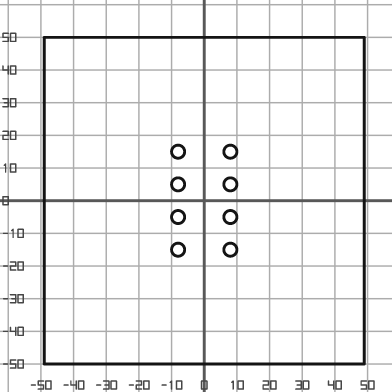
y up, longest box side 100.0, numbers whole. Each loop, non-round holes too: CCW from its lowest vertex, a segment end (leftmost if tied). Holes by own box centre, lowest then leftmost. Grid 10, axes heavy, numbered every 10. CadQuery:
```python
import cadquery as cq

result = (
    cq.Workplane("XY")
    .moveTo(-49.0, -50.0)
    .lineTo(49.0, -50.0)
    .lineTo(49.0, 50.0)
    .lineTo(-49.0, 50.0)
    .close()
    .moveTo(-8.0, -15.0)
    .circle(2.0)
    .moveTo(8.0, -15.0)
    .circle(2.0)
    .moveTo(-8.0, -5.0)
    .circle(2.0)
    .moveTo(8.0, -5.0)
    .circle(2.0)
    .moveTo(-8.0, 5.0)
    .circle(2.0)
    .moveTo(8.0, 5.0)
    .circle(2.0)
    .moveTo(-8.0, 15.0)
    .circle(2.0)
    .moveTo(8.0, 15.0)
    .circle(2.0)
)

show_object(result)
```